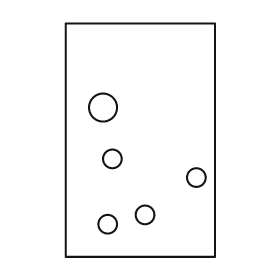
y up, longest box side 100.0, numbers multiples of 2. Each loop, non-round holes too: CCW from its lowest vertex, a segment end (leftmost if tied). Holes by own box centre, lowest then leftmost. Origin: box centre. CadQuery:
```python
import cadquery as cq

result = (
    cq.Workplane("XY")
    .moveTo(-32.0, -50.0)
    .lineTo(32.0, -50.0)
    .lineTo(32.0, 50.0)
    .lineTo(-32.0, 50.0)
    .close()
    .moveTo(-14.0, -36.0)
    .circle(4.0)
    .moveTo(2.0, -32.0)
    .circle(4.0)
    .moveTo(24.0, -16.0)
    .circle(4.0)
    .moveTo(-12.0, -8.0)
    .circle(4.0)
    .moveTo(-16.0, 14.0)
    .circle(6.0)
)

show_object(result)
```